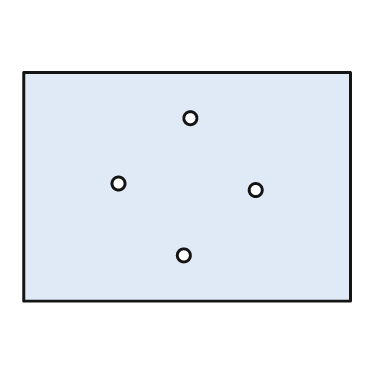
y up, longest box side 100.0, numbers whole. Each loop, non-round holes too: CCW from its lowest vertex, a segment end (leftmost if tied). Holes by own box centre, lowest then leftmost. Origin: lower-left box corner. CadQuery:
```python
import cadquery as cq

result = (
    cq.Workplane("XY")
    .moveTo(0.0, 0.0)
    .lineTo(100.0, 0.0)
    .lineTo(100.0, 70.0)
    .lineTo(0.0, 70.0)
    .close()
    .moveTo(49.0, 14.0)
    .circle(2.0)
    .moveTo(71.0, 34.0)
    .circle(2.0)
    .moveTo(29.0, 36.0)
    .circle(2.0)
    .moveTo(51.0, 56.0)
    .circle(2.0)
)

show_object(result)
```